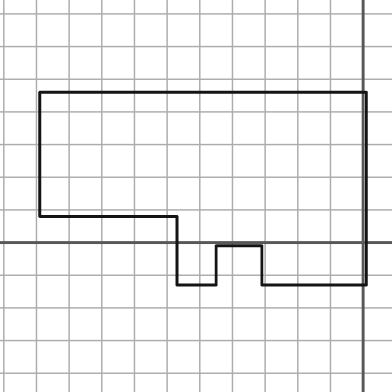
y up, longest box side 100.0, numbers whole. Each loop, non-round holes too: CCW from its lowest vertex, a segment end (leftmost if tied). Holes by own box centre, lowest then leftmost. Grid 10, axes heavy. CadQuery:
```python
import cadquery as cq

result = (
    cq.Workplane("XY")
    .moveTo(-57.0, -13.0)
    .lineTo(-45.0, -13.0)
    .lineTo(-45.0, -1.0)
    .lineTo(-31.0, -1.0)
    .lineTo(-31.0, -13.0)
    .lineTo(1.0, -13.0)
    .lineTo(1.0, 46.0)
    .lineTo(-99.0, 46.0)
    .lineTo(-99.0, 8.0)
    .lineTo(-57.0, 8.0)
    .close()
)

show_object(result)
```